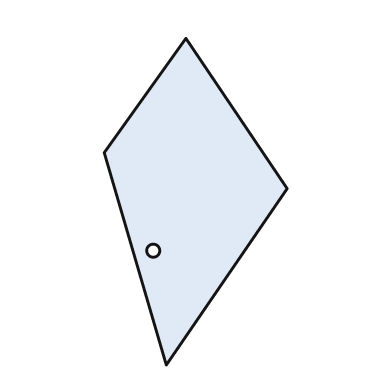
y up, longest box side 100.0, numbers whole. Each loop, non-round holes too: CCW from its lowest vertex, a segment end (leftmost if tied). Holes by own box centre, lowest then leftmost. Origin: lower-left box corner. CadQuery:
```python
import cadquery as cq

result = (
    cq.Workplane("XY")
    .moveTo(19.0, 0.0)
    .lineTo(56.0, 54.0)
    .lineTo(25.0, 100.0)
    .lineTo(0.0, 65.0)
    .close()
    .moveTo(15.0, 35.0)
    .circle(2.0)
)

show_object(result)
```